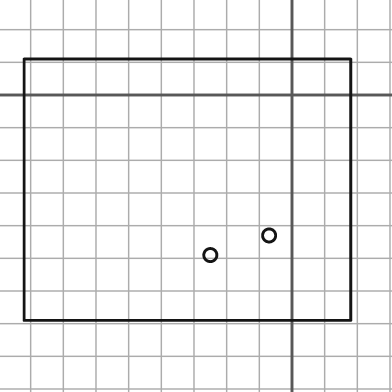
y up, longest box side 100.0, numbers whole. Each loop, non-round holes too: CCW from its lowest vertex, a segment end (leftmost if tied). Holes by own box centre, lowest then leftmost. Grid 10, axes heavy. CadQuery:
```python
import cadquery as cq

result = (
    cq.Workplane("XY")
    .moveTo(-82.0, -69.0)
    .lineTo(18.0, -69.0)
    .lineTo(18.0, 11.0)
    .lineTo(-82.0, 11.0)
    .close()
    .moveTo(-25.0, -49.0)
    .circle(2.0)
    .moveTo(-7.0, -43.0)
    .circle(2.0)
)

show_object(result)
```